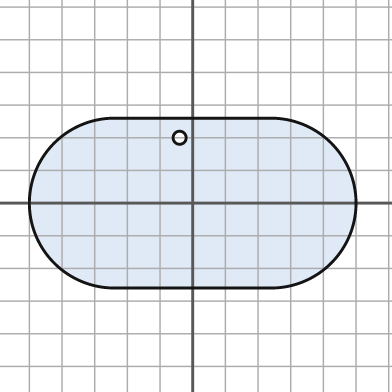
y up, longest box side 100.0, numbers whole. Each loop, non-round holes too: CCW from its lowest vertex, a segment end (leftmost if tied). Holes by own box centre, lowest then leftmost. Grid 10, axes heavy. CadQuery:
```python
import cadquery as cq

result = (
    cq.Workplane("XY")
    .moveTo(-24.0, -26.0)
    .lineTo(24.0, -26.0)
    .threePointArc((50.0, 0.0), (24.0, 26.0))
    .lineTo(-24.0, 26.0)
    .threePointArc((-50.0, 0.0), (-24.0, -26.0))
    .close()
    .moveTo(-4.0, 20.0)
    .circle(2.0)
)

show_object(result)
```